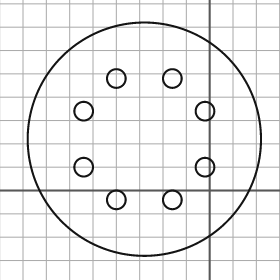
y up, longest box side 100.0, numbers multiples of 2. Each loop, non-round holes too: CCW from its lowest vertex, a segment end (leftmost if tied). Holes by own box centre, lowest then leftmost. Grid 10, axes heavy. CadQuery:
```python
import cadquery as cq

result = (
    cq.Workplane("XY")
    .moveTo(-28.0, 22.0)
    .circle(50.0)
    .moveTo(-40.0, -4.0)
    .circle(4.0)
    .moveTo(-16.0, -4.0)
    .circle(4.0)
    .moveTo(-54.0, 10.0)
    .circle(4.0)
    .moveTo(-2.0, 10.0)
    .circle(4.0)
    .moveTo(-54.0, 34.0)
    .circle(4.0)
    .moveTo(-2.0, 34.0)
    .circle(4.0)
    .moveTo(-40.0, 48.0)
    .circle(4.0)
    .moveTo(-16.0, 48.0)
    .circle(4.0)
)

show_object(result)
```